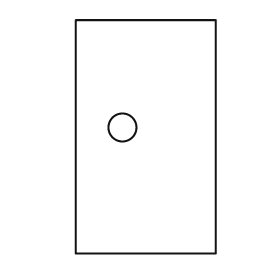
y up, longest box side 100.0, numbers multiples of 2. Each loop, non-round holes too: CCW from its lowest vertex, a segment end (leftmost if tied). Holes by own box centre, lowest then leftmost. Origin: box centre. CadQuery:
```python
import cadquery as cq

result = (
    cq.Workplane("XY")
    .moveTo(-30.0, -50.0)
    .lineTo(30.0, -50.0)
    .lineTo(30.0, 50.0)
    .lineTo(-30.0, 50.0)
    .close()
    .moveTo(-10.0, 4.0)
    .circle(6.0)
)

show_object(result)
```